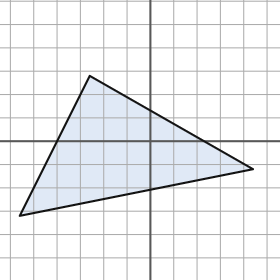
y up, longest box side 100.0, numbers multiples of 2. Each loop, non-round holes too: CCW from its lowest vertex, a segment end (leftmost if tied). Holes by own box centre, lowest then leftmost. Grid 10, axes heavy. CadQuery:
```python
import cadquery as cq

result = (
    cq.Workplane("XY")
    .moveTo(-56.0, -32.0)
    .lineTo(44.0, -12.0)
    .lineTo(-26.0, 28.0)
    .close()
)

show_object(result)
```